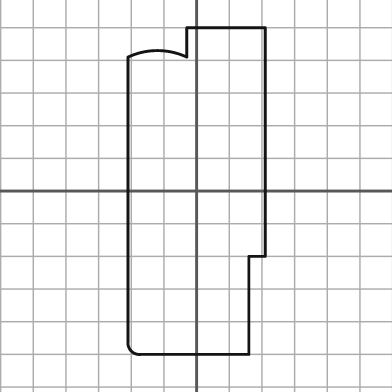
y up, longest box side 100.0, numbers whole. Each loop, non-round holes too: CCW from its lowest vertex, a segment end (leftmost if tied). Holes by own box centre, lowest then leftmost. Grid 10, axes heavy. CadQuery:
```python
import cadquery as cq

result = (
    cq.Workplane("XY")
    .moveTo(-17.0, -50.0)
    .lineTo(16.0, -50.0)
    .lineTo(16.0, -20.0)
    .lineTo(21.0, -20.0)
    .lineTo(21.0, 50.0)
    .lineTo(-3.0, 50.0)
    .lineTo(-3.0, 41.0)
    .threePointArc((-12.0, 43.0), (-21.0, 41.0))
    .lineTo(-21.0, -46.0)
    .threePointArc((-20.0, -49.0), (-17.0, -50.0))
    .close()
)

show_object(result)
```